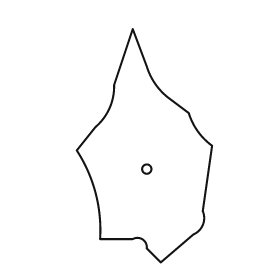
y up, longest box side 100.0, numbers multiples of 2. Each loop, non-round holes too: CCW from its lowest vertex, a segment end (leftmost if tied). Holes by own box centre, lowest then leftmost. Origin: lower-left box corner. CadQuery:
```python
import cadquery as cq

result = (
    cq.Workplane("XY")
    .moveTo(36.0, 0.0)
    .lineTo(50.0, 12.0)
    .threePointArc((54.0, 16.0), (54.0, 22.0))
    .lineTo(58.0, 50.0)
    .threePointArc((52.0, 56.0), (48.0, 64.0))
    .lineTo(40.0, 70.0)
    .threePointArc((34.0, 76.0), (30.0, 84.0))
    .lineTo(24.0, 100.0)
    .lineTo(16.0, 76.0)
    .threePointArc((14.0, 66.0), (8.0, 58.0))
    .lineTo(0.0, 48.0)
    .threePointArc((8.0, 30.0), (10.0, 10.0))
    .lineTo(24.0, 10.0)
    .threePointArc((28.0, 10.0), (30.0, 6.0))
    .close()
    .moveTo(30.0, 40.0)
    .circle(2.0)
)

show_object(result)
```